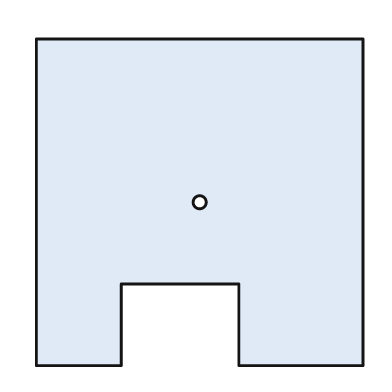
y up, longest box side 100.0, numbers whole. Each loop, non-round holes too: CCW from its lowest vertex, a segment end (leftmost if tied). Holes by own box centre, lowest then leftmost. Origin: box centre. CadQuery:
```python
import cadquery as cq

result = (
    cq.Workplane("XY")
    .moveTo(-50.0, -50.0)
    .lineTo(-24.0, -50.0)
    .lineTo(-24.0, -25.0)
    .lineTo(12.0, -25.0)
    .lineTo(12.0, -50.0)
    .lineTo(50.0, -50.0)
    .lineTo(50.0, 50.0)
    .lineTo(-50.0, 50.0)
    .close()
    .moveTo(0.0, 0.0)
    .circle(2.0)
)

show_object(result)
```